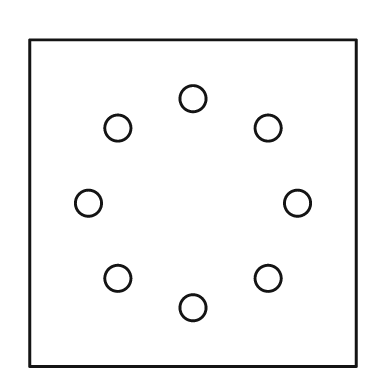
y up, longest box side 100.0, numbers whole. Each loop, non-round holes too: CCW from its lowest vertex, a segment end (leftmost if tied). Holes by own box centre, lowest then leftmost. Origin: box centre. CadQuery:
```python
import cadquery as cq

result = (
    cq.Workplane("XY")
    .moveTo(-50.0, -50.0)
    .lineTo(50.0, -50.0)
    .lineTo(50.0, 50.0)
    .lineTo(-50.0, 50.0)
    .close()
    .moveTo(0.0, -32.0)
    .circle(4.0)
    .moveTo(-23.0, -23.0)
    .circle(4.0)
    .moveTo(23.0, -23.0)
    .circle(4.0)
    .moveTo(-32.0, 0.0)
    .circle(4.0)
    .moveTo(32.0, 0.0)
    .circle(4.0)
    .moveTo(-23.0, 23.0)
    .circle(4.0)
    .moveTo(23.0, 23.0)
    .circle(4.0)
    .moveTo(0.0, 32.0)
    .circle(4.0)
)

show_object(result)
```